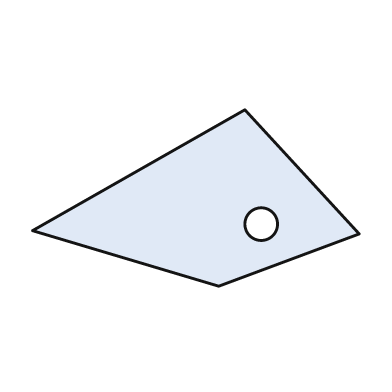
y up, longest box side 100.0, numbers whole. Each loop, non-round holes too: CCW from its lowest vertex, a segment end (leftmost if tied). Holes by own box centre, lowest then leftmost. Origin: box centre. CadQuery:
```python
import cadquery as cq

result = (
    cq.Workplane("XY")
    .moveTo(7.0, -27.0)
    .lineTo(50.0, -11.0)
    .lineTo(15.0, 27.0)
    .lineTo(-50.0, -10.0)
    .close()
    .moveTo(20.0, -8.0)
    .circle(5.0)
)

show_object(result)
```